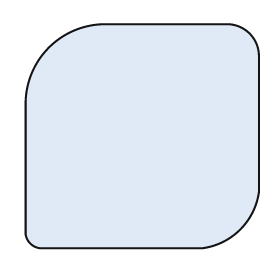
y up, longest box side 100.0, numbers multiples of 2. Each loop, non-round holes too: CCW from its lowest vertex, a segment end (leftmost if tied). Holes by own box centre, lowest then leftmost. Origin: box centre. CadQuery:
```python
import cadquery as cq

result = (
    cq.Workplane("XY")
    .moveTo(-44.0, -48.0)
    .lineTo(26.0, -48.0)
    .threePointArc((42.0, -40.0), (50.0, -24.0))
    .lineTo(50.0, 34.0)
    .threePointArc((46.0, 44.0), (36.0, 48.0))
    .lineTo(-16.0, 48.0)
    .threePointArc((-40.0, 38.0), (-50.0, 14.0))
    .lineTo(-50.0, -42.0)
    .threePointArc((-48.0, -46.0), (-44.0, -48.0))
    .close()
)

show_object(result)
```